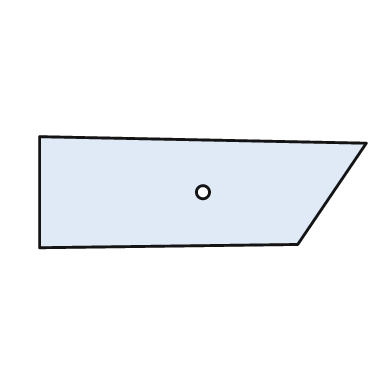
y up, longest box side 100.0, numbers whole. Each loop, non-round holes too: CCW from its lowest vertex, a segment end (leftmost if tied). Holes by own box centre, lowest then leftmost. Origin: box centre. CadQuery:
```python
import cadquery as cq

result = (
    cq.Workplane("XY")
    .moveTo(-50.0, -17.0)
    .lineTo(29.0, -16.0)
    .lineTo(50.0, 15.0)
    .lineTo(-50.0, 17.0)
    .close()
    .moveTo(0.0, 0.0)
    .circle(2.0)
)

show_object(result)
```